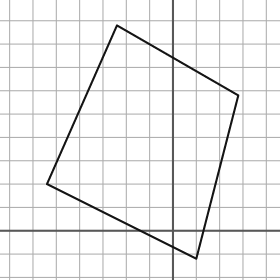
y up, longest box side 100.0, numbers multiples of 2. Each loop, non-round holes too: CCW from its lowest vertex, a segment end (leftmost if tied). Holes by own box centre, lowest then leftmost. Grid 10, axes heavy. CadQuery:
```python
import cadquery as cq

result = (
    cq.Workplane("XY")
    .moveTo(10.0, -12.0)
    .lineTo(28.0, 58.0)
    .lineTo(-24.0, 88.0)
    .lineTo(-54.0, 20.0)
    .close()
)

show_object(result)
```